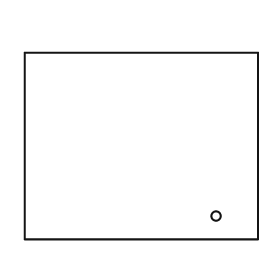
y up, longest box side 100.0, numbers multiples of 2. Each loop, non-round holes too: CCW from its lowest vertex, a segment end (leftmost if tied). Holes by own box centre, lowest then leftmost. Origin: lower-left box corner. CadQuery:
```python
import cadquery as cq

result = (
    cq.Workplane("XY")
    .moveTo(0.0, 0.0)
    .lineTo(100.0, 0.0)
    .lineTo(100.0, 80.0)
    .lineTo(0.0, 80.0)
    .close()
    .moveTo(82.0, 10.0)
    .circle(2.0)
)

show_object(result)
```